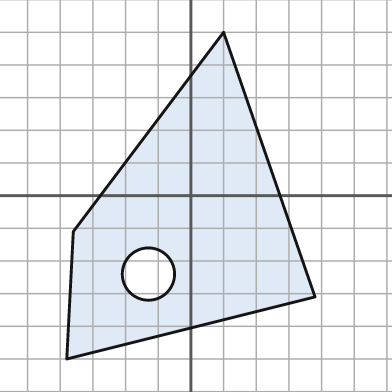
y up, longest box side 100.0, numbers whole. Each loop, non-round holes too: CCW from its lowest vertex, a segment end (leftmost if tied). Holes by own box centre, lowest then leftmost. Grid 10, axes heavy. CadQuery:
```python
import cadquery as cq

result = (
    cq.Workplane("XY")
    .moveTo(-38.0, -50.0)
    .lineTo(38.0, -31.0)
    .lineTo(10.0, 50.0)
    .lineTo(-36.0, -11.0)
    .close()
    .moveTo(-13.0, -24.0)
    .circle(8.0)
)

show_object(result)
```